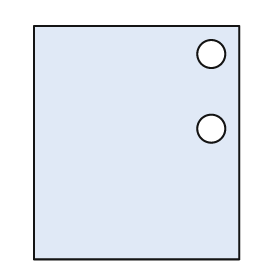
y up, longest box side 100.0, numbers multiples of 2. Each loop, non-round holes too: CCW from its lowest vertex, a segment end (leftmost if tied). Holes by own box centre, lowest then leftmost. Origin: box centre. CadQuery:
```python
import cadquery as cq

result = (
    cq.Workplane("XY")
    .moveTo(-44.0, -50.0)
    .lineTo(44.0, -50.0)
    .lineTo(44.0, 50.0)
    .lineTo(-44.0, 50.0)
    .close()
    .moveTo(32.0, 6.0)
    .circle(6.0)
    .moveTo(32.0, 38.0)
    .circle(6.0)
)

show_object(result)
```